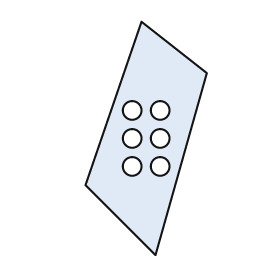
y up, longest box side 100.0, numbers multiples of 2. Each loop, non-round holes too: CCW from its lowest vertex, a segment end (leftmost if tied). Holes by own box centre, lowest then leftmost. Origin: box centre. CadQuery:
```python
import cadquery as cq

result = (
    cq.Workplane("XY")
    .moveTo(4.0, -50.0)
    .lineTo(26.0, 28.0)
    .lineTo(-2.0, 50.0)
    .lineTo(-26.0, -20.0)
    .close()
    .moveTo(-6.0, -12.0)
    .circle(4.0)
    .moveTo(6.0, -12.0)
    .circle(4.0)
    .moveTo(-6.0, 0.0)
    .circle(4.0)
    .moveTo(6.0, 0.0)
    .circle(4.0)
    .moveTo(-6.0, 12.0)
    .circle(4.0)
    .moveTo(6.0, 12.0)
    .circle(4.0)
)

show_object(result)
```